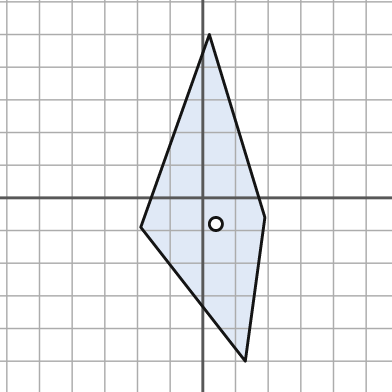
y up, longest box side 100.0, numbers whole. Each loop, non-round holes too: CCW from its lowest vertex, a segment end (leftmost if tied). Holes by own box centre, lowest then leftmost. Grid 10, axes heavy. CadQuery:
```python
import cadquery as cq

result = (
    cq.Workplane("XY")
    .moveTo(13.0, -50.0)
    .lineTo(19.0, -6.0)
    .lineTo(2.0, 50.0)
    .lineTo(-19.0, -9.0)
    .close()
    .moveTo(4.0, -8.0)
    .circle(2.0)
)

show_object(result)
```